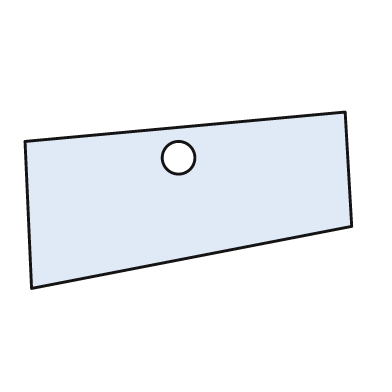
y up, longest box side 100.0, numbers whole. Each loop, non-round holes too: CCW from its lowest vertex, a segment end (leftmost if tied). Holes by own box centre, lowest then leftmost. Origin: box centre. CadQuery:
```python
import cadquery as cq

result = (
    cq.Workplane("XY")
    .moveTo(-48.0, -27.0)
    .lineTo(50.0, -8.0)
    .lineTo(48.0, 27.0)
    .lineTo(-50.0, 18.0)
    .close()
    .moveTo(-3.0, 13.0)
    .circle(5.0)
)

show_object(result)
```